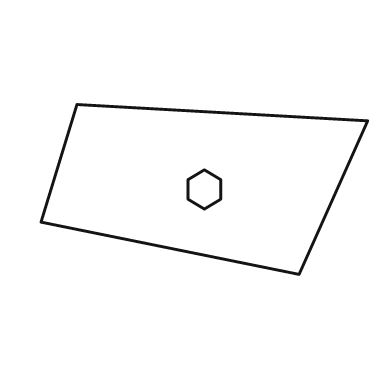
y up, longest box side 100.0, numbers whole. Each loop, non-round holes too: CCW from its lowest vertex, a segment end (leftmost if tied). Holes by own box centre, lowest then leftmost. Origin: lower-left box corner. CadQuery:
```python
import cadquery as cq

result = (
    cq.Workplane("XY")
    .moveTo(79.0, 0.0)
    .lineTo(100.0, 47.0)
    .lineTo(11.0, 52.0)
    .lineTo(0.0, 16.0)
    .close()
    .moveTo(50.0, 20.0)
    .lineTo(55.0, 23.0)
    .lineTo(55.0, 29.0)
    .lineTo(50.0, 32.0)
    .lineTo(45.0, 29.0)
    .lineTo(45.0, 23.0)
    .close()
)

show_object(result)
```